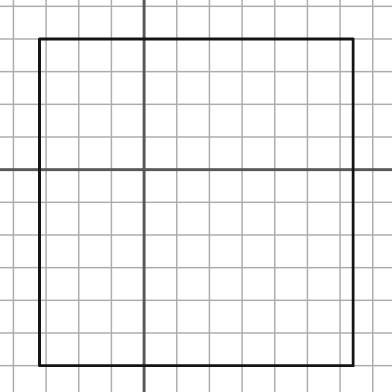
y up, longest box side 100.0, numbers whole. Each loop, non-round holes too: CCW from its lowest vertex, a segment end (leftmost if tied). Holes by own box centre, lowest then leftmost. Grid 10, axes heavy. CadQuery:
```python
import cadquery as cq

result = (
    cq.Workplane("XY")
    .moveTo(-32.0, -60.0)
    .lineTo(64.0, -60.0)
    .lineTo(64.0, 40.0)
    .lineTo(-32.0, 40.0)
    .close()
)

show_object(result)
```